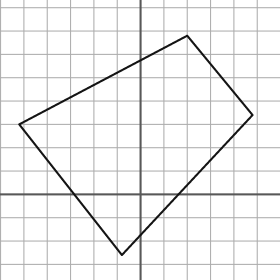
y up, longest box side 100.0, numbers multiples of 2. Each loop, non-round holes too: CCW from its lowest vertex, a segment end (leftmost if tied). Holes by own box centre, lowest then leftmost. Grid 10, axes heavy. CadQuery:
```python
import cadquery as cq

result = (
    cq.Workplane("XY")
    .moveTo(-8.0, -26.0)
    .lineTo(48.0, 34.0)
    .lineTo(20.0, 68.0)
    .lineTo(-52.0, 30.0)
    .close()
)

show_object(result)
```